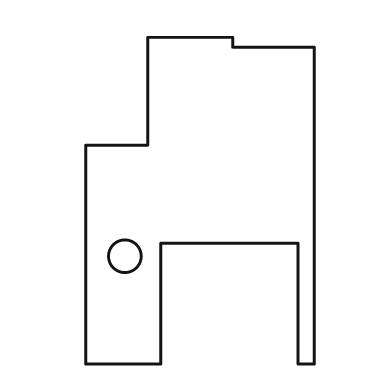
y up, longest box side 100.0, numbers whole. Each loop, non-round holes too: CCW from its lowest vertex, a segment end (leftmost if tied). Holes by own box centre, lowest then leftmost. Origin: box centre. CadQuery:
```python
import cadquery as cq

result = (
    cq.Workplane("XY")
    .moveTo(-35.0, -50.0)
    .lineTo(-12.0, -50.0)
    .lineTo(-12.0, -13.0)
    .lineTo(30.0, -13.0)
    .lineTo(30.0, -50.0)
    .lineTo(35.0, -50.0)
    .lineTo(35.0, 47.0)
    .lineTo(10.0, 47.0)
    .lineTo(10.0, 50.0)
    .lineTo(-16.0, 50.0)
    .lineTo(-16.0, 17.0)
    .lineTo(-35.0, 17.0)
    .close()
    .moveTo(-23.0, -17.0)
    .circle(5.0)
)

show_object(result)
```